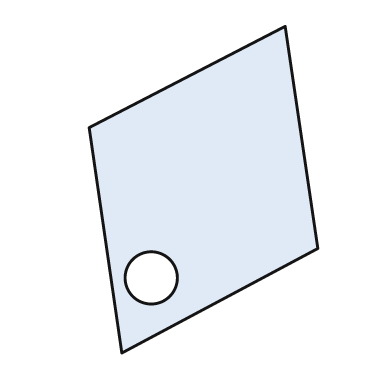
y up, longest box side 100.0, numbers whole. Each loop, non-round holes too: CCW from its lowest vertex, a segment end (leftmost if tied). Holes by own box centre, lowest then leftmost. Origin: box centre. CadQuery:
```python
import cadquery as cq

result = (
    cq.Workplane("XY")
    .moveTo(-25.0, -50.0)
    .lineTo(35.0, -18.0)
    .lineTo(25.0, 50.0)
    .lineTo(-35.0, 19.0)
    .close()
    .moveTo(-16.0, -27.0)
    .circle(8.0)
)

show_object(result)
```